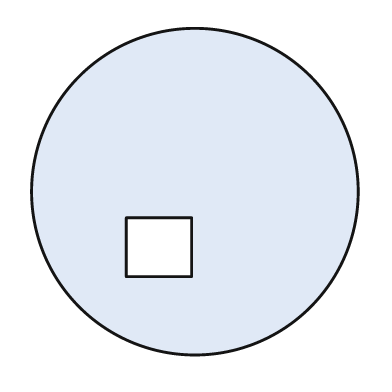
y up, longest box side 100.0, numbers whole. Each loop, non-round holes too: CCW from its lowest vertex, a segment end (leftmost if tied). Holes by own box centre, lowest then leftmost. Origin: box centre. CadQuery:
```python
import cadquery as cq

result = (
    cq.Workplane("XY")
    .moveTo(0.0, 0.0)
    .circle(50.0)
    .moveTo(-21.0, -26.0)
    .lineTo(-1.0, -26.0)
    .lineTo(-1.0, -8.0)
    .lineTo(-21.0, -8.0)
    .close()
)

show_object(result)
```